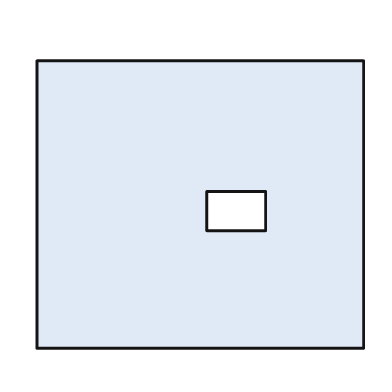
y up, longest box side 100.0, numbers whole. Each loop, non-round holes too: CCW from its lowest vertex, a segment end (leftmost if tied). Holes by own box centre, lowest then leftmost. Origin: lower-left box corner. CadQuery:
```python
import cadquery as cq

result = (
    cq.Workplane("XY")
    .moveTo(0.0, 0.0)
    .lineTo(100.0, 0.0)
    .lineTo(100.0, 88.0)
    .lineTo(0.0, 88.0)
    .close()
    .moveTo(52.0, 36.0)
    .lineTo(70.0, 36.0)
    .lineTo(70.0, 48.0)
    .lineTo(52.0, 48.0)
    .close()
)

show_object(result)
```